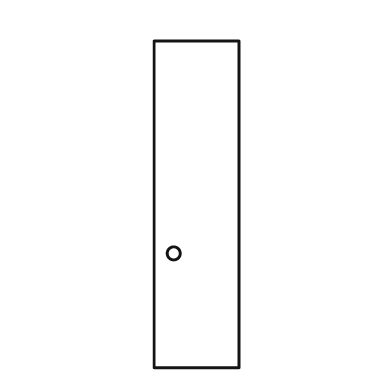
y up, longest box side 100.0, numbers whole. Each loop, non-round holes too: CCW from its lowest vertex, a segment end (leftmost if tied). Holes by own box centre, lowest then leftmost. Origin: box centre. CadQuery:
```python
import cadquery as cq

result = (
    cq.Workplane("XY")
    .moveTo(-13.0, -50.0)
    .lineTo(13.0, -50.0)
    .lineTo(13.0, 50.0)
    .lineTo(-13.0, 50.0)
    .close()
    .moveTo(-7.0, -15.0)
    .circle(2.0)
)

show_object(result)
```